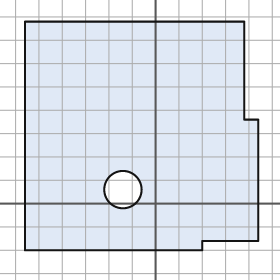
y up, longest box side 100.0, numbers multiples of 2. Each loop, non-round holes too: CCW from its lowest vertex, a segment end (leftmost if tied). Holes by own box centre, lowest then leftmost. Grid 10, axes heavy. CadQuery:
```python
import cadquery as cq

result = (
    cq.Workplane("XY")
    .moveTo(-56.0, -20.0)
    .lineTo(20.0, -20.0)
    .lineTo(20.0, -16.0)
    .lineTo(44.0, -16.0)
    .lineTo(44.0, 36.0)
    .lineTo(38.0, 36.0)
    .lineTo(38.0, 78.0)
    .lineTo(-56.0, 78.0)
    .close()
    .moveTo(-14.0, 6.0)
    .circle(8.0)
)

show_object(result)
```